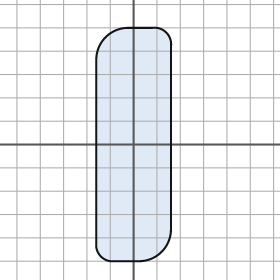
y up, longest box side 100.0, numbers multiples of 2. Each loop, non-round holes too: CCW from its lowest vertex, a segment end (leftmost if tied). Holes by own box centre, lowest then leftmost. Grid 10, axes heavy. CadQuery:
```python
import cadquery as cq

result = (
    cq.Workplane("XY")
    .moveTo(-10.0, -50.0)
    .lineTo(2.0, -50.0)
    .threePointArc((12.0, -46.0), (16.0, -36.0))
    .lineTo(16.0, 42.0)
    .threePointArc((14.0, 48.0), (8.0, 50.0))
    .lineTo(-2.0, 50.0)
    .threePointArc((-12.0, 46.0), (-16.0, 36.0))
    .lineTo(-16.0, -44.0)
    .threePointArc((-14.0, -48.0), (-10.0, -50.0))
    .close()
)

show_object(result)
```